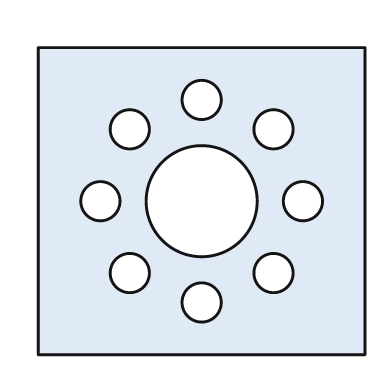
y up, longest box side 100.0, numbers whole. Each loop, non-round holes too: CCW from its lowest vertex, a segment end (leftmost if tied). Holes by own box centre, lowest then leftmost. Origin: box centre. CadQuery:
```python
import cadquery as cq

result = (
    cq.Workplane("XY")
    .moveTo(-50.0, -47.0)
    .lineTo(50.0, -47.0)
    .lineTo(50.0, 47.0)
    .lineTo(-50.0, 47.0)
    .close()
    .moveTo(0.0, -31.0)
    .circle(6.0)
    .moveTo(-22.0, -22.0)
    .circle(6.0)
    .moveTo(22.0, -22.0)
    .circle(6.0)
    .moveTo(-31.0, 0.0)
    .circle(6.0)
    .moveTo(0.0, 0.0)
    .circle(17.0)
    .moveTo(31.0, 0.0)
    .circle(6.0)
    .moveTo(-22.0, 22.0)
    .circle(6.0)
    .moveTo(22.0, 22.0)
    .circle(6.0)
    .moveTo(0.0, 31.0)
    .circle(6.0)
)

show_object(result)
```